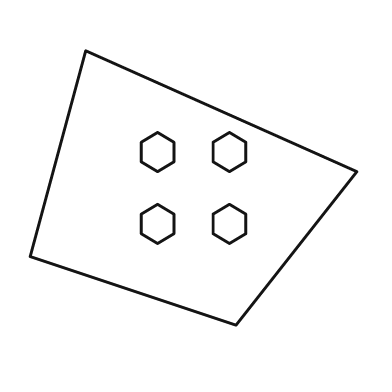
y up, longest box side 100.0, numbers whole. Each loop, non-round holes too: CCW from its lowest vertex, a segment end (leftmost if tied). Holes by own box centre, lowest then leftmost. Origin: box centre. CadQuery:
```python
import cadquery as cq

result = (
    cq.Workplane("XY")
    .moveTo(13.0, -42.0)
    .lineTo(50.0, 5.0)
    .lineTo(-33.0, 42.0)
    .lineTo(-50.0, -21.0)
    .close()
    .moveTo(-11.0, -17.0)
    .lineTo(-6.0, -14.0)
    .lineTo(-6.0, -8.0)
    .lineTo(-11.0, -5.0)
    .lineTo(-16.0, -8.0)
    .lineTo(-16.0, -14.0)
    .close()
    .moveTo(11.0, -17.0)
    .lineTo(16.0, -14.0)
    .lineTo(16.0, -8.0)
    .lineTo(11.0, -5.0)
    .lineTo(6.0, -8.0)
    .lineTo(6.0, -14.0)
    .close()
    .moveTo(-11.0, 5.0)
    .lineTo(-6.0, 8.0)
    .lineTo(-6.0, 14.0)
    .lineTo(-11.0, 17.0)
    .lineTo(-16.0, 14.0)
    .lineTo(-16.0, 8.0)
    .close()
    .moveTo(11.0, 5.0)
    .lineTo(16.0, 8.0)
    .lineTo(16.0, 14.0)
    .lineTo(11.0, 17.0)
    .lineTo(6.0, 14.0)
    .lineTo(6.0, 8.0)
    .close()
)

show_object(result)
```